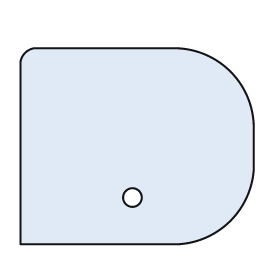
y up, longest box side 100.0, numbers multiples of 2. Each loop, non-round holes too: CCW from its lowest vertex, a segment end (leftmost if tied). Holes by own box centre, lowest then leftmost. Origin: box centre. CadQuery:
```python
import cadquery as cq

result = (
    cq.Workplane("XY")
    .moveTo(-50.0, -42.0)
    .lineTo(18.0, -42.0)
    .threePointArc((40.0, -32.0), (50.0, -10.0))
    .lineTo(50.0, 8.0)
    .threePointArc((40.0, 32.0), (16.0, 42.0))
    .lineTo(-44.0, 42.0)
    .threePointArc((-48.0, 40.0), (-50.0, 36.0))
    .close()
    .moveTo(-2.0, -22.0)
    .circle(4.0)
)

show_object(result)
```